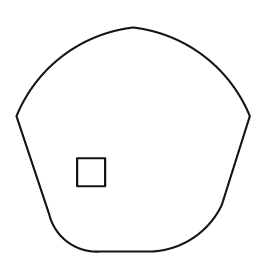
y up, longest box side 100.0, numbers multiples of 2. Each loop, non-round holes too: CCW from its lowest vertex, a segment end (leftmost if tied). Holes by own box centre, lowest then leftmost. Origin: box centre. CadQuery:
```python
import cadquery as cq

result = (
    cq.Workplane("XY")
    .moveTo(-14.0, -48.0)
    .lineTo(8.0, -48.0)
    .threePointArc((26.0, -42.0), (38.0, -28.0))
    .lineTo(50.0, 10.0)
    .threePointArc((30.0, 36.0), (0.0, 48.0))
    .threePointArc((-30.0, 36.0), (-50.0, 10.0))
    .lineTo(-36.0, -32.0)
    .threePointArc((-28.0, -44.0), (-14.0, -48.0))
    .close()
    .moveTo(-24.0, -20.0)
    .lineTo(-12.0, -20.0)
    .lineTo(-12.0, -8.0)
    .lineTo(-24.0, -8.0)
    .close()
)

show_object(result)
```